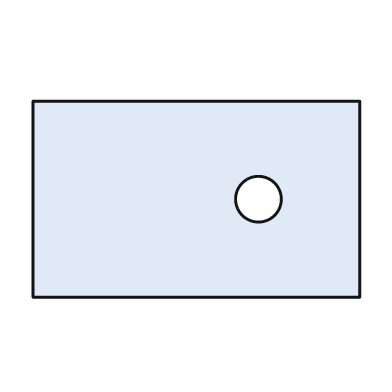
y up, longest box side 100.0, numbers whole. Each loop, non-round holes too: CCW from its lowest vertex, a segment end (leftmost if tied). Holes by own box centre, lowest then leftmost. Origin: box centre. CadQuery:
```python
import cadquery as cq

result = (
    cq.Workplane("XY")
    .moveTo(-50.0, -30.0)
    .lineTo(50.0, -30.0)
    .lineTo(50.0, 30.0)
    .lineTo(-50.0, 30.0)
    .close()
    .moveTo(19.0, 0.0)
    .circle(7.0)
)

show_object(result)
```